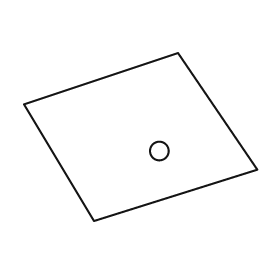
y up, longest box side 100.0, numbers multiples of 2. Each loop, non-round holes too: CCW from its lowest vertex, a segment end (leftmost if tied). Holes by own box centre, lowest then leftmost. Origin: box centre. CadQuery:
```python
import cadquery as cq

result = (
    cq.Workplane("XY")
    .moveTo(-20.0, -36.0)
    .lineTo(50.0, -14.0)
    .lineTo(16.0, 36.0)
    .lineTo(-50.0, 14.0)
    .close()
    .moveTo(8.0, -6.0)
    .circle(4.0)
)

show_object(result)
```